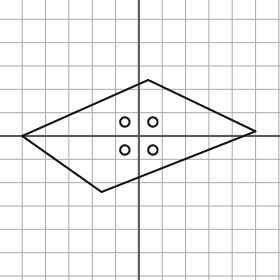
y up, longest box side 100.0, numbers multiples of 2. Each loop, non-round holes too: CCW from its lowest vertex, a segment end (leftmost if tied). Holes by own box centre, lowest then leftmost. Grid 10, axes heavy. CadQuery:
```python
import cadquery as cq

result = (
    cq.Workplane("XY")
    .moveTo(-16.0, -24.0)
    .lineTo(50.0, 2.0)
    .lineTo(4.0, 24.0)
    .lineTo(-50.0, 0.0)
    .close()
    .moveTo(-6.0, -6.0)
    .circle(2.0)
    .moveTo(6.0, -6.0)
    .circle(2.0)
    .moveTo(-6.0, 6.0)
    .circle(2.0)
    .moveTo(6.0, 6.0)
    .circle(2.0)
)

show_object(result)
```